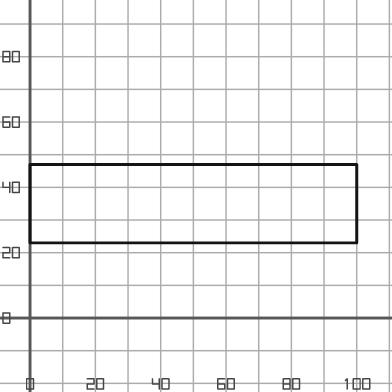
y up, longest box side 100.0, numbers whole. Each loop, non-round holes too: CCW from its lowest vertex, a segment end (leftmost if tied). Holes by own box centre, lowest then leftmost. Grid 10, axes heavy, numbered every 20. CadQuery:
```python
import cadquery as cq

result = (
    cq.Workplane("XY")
    .moveTo(0.0, 23.0)
    .lineTo(100.0, 23.0)
    .lineTo(100.0, 47.0)
    .lineTo(0.0, 47.0)
    .close()
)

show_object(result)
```